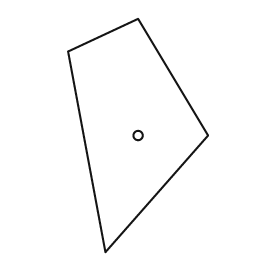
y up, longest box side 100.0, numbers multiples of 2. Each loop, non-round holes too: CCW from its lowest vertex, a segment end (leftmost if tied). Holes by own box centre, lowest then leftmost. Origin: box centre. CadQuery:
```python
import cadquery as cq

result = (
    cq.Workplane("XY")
    .moveTo(-14.0, -50.0)
    .lineTo(30.0, 0.0)
    .lineTo(0.0, 50.0)
    .lineTo(-30.0, 36.0)
    .close()
    .moveTo(0.0, 0.0)
    .circle(2.0)
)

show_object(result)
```